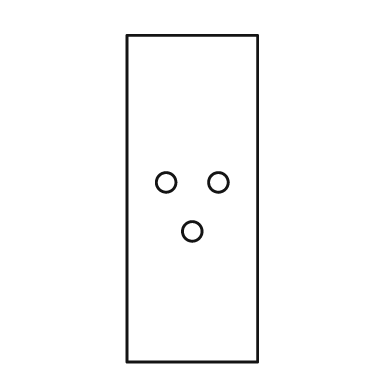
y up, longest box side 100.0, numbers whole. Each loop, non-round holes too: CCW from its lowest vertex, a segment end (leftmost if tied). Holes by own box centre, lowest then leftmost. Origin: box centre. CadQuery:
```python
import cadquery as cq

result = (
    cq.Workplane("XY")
    .moveTo(-20.0, -50.0)
    .lineTo(20.0, -50.0)
    .lineTo(20.0, 50.0)
    .lineTo(-20.0, 50.0)
    .close()
    .moveTo(0.0, -10.0)
    .circle(3.0)
    .moveTo(-8.0, 5.0)
    .circle(3.0)
    .moveTo(8.0, 5.0)
    .circle(3.0)
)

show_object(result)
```